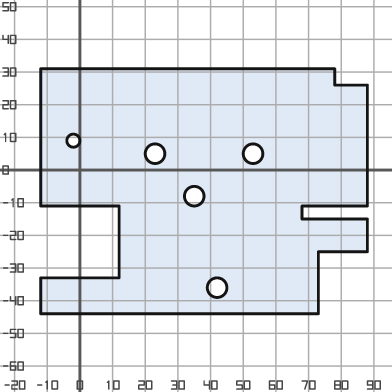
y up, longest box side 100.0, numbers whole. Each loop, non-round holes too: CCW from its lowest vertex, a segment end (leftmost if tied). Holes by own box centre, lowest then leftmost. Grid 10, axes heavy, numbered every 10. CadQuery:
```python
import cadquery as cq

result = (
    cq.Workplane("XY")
    .moveTo(-12.0, -44.0)
    .lineTo(73.0, -44.0)
    .lineTo(73.0, -25.0)
    .lineTo(88.0, -25.0)
    .lineTo(88.0, -15.0)
    .lineTo(68.0, -15.0)
    .lineTo(68.0, -11.0)
    .lineTo(88.0, -11.0)
    .lineTo(88.0, 26.0)
    .lineTo(78.0, 26.0)
    .lineTo(78.0, 31.0)
    .lineTo(-12.0, 31.0)
    .lineTo(-12.0, -11.0)
    .lineTo(12.0, -11.0)
    .lineTo(12.0, -33.0)
    .lineTo(-12.0, -33.0)
    .close()
    .moveTo(42.0, -36.0)
    .circle(3.0)
    .moveTo(35.0, -8.0)
    .circle(3.0)
    .moveTo(23.0, 5.0)
    .circle(3.0)
    .moveTo(53.0, 5.0)
    .circle(3.0)
    .moveTo(-2.0, 9.0)
    .circle(2.0)
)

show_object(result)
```